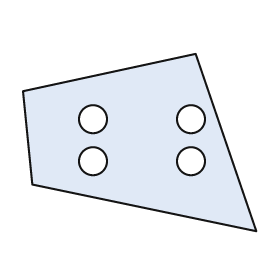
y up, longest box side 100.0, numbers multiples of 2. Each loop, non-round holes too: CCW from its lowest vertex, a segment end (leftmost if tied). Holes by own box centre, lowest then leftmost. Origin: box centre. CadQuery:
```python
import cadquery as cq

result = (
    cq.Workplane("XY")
    .moveTo(50.0, -38.0)
    .lineTo(24.0, 38.0)
    .lineTo(-50.0, 22.0)
    .lineTo(-46.0, -18.0)
    .close()
    .moveTo(-20.0, -8.0)
    .circle(6.0)
    .moveTo(22.0, -8.0)
    .circle(6.0)
    .moveTo(-20.0, 10.0)
    .circle(6.0)
    .moveTo(22.0, 10.0)
    .circle(6.0)
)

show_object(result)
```